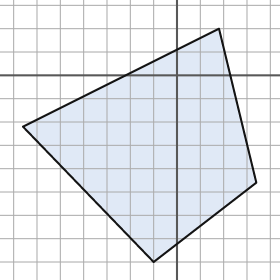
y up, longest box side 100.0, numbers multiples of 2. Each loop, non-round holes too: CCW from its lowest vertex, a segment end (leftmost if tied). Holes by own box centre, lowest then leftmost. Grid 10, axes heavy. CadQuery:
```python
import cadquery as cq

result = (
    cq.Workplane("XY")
    .moveTo(-10.0, -80.0)
    .lineTo(34.0, -46.0)
    .lineTo(18.0, 20.0)
    .lineTo(-66.0, -22.0)
    .close()
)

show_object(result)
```